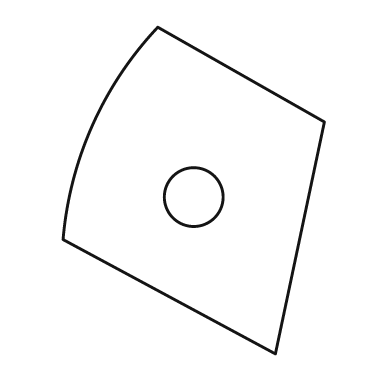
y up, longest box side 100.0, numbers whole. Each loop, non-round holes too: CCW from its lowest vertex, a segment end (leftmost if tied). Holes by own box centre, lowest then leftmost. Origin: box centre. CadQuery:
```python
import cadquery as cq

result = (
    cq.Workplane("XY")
    .moveTo(25.0, -50.0)
    .lineTo(40.0, 21.0)
    .lineTo(-11.0, 50.0)
    .threePointArc((-31.0, 20.0), (-40.0, -15.0))
    .close()
    .moveTo(0.0, -2.0)
    .circle(9.0)
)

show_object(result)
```